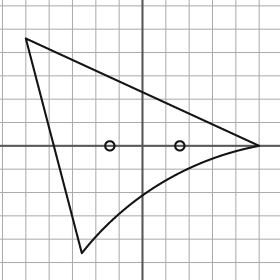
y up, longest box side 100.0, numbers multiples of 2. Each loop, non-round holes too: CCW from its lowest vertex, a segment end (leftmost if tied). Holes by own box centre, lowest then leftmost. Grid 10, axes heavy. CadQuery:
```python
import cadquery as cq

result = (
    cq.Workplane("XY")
    .moveTo(-26.0, -46.0)
    .threePointArc((8.0, -16.0), (50.0, 0.0))
    .lineTo(-50.0, 46.0)
    .close()
    .moveTo(-14.0, 0.0)
    .circle(2.0)
    .moveTo(16.0, 0.0)
    .circle(2.0)
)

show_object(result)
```